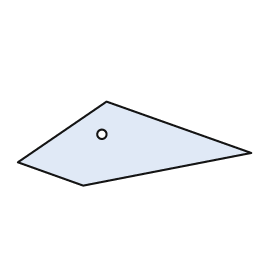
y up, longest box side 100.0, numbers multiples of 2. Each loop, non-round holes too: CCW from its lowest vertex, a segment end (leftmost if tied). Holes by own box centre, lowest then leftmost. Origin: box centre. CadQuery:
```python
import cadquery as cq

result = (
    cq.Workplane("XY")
    .moveTo(-22.0, -18.0)
    .lineTo(50.0, -4.0)
    .lineTo(-12.0, 18.0)
    .lineTo(-50.0, -8.0)
    .close()
    .moveTo(-14.0, 4.0)
    .circle(2.0)
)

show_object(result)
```